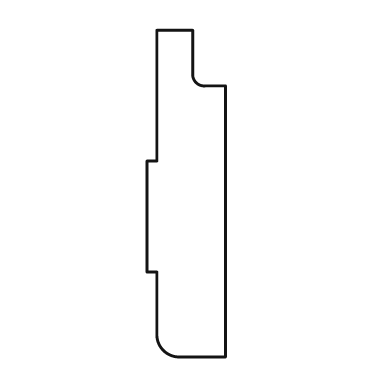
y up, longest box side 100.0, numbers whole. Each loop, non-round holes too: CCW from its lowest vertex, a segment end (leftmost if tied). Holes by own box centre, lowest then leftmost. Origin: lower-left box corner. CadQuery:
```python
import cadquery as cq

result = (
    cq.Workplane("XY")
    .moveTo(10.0, 0.0)
    .lineTo(24.0, 0.0)
    .lineTo(24.0, 83.0)
    .lineTo(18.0, 83.0)
    .threePointArc((15.0, 84.0), (14.0, 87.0))
    .lineTo(14.0, 100.0)
    .lineTo(3.0, 100.0)
    .lineTo(3.0, 60.0)
    .lineTo(0.0, 60.0)
    .lineTo(0.0, 26.0)
    .lineTo(3.0, 26.0)
    .lineTo(3.0, 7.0)
    .threePointArc((5.0, 2.0), (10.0, 0.0))
    .close()
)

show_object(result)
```